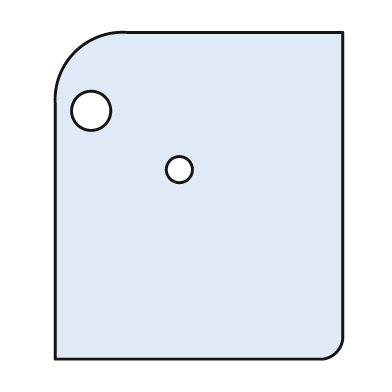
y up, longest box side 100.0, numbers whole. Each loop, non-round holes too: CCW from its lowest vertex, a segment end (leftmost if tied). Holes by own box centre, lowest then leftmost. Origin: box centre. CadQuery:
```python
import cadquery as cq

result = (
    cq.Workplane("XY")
    .moveTo(-44.0, -50.0)
    .lineTo(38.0, -50.0)
    .threePointArc((42.0, -48.0), (44.0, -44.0))
    .lineTo(44.0, 50.0)
    .lineTo(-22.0, 50.0)
    .threePointArc((-38.0, 44.0), (-44.0, 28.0))
    .close()
    .moveTo(-6.0, 8.0)
    .circle(4.0)
    .moveTo(-33.0, 26.0)
    .circle(6.0)
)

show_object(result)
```